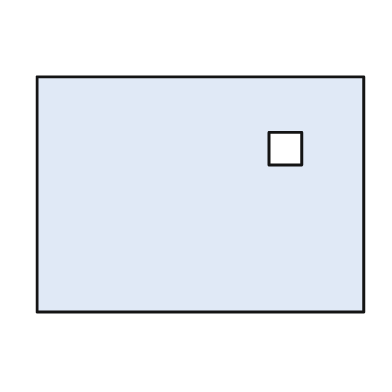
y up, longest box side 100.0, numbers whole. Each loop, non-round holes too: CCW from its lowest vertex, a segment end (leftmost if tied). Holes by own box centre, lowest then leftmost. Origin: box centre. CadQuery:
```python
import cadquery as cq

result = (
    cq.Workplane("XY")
    .moveTo(-50.0, -36.0)
    .lineTo(50.0, -36.0)
    .lineTo(50.0, 36.0)
    .lineTo(-50.0, 36.0)
    .close()
    .moveTo(21.0, 9.0)
    .lineTo(31.0, 9.0)
    .lineTo(31.0, 19.0)
    .lineTo(21.0, 19.0)
    .close()
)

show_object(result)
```